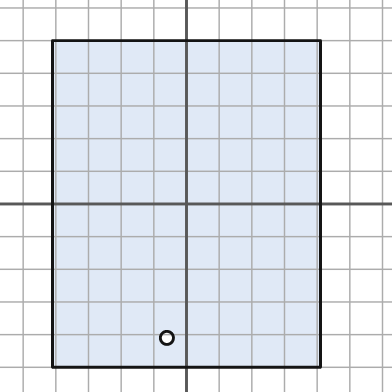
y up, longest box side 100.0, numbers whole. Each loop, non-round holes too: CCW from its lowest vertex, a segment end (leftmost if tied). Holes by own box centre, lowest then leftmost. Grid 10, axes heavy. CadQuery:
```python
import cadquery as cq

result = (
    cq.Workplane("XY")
    .moveTo(-41.0, -50.0)
    .lineTo(41.0, -50.0)
    .lineTo(41.0, 50.0)
    .lineTo(-41.0, 50.0)
    .close()
    .moveTo(-6.0, -41.0)
    .circle(2.0)
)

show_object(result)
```